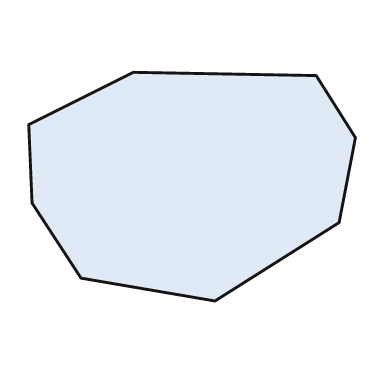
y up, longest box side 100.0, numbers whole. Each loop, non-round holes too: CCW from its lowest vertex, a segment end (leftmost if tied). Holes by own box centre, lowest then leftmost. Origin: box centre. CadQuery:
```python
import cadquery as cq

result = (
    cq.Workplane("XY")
    .moveTo(7.0, -35.0)
    .lineTo(45.0, -11.0)
    .lineTo(50.0, 15.0)
    .lineTo(38.0, 34.0)
    .lineTo(-18.0, 35.0)
    .lineTo(-50.0, 19.0)
    .lineTo(-49.0, -5.0)
    .lineTo(-34.0, -28.0)
    .close()
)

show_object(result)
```